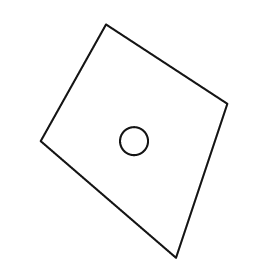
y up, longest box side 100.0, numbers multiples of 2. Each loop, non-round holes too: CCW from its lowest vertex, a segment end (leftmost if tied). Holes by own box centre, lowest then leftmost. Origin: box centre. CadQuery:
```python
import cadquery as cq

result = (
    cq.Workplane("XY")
    .moveTo(18.0, -50.0)
    .lineTo(40.0, 16.0)
    .lineTo(-12.0, 50.0)
    .lineTo(-40.0, 0.0)
    .close()
    .moveTo(0.0, 0.0)
    .circle(6.0)
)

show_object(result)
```